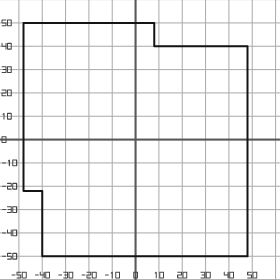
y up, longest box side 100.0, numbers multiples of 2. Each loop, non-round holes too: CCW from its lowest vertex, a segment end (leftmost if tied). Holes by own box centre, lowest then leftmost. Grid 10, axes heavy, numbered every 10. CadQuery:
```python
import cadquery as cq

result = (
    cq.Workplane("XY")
    .moveTo(-40.0, -50.0)
    .lineTo(48.0, -50.0)
    .lineTo(48.0, 40.0)
    .lineTo(8.0, 40.0)
    .lineTo(8.0, 50.0)
    .lineTo(-48.0, 50.0)
    .lineTo(-48.0, -22.0)
    .lineTo(-40.0, -22.0)
    .close()
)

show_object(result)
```